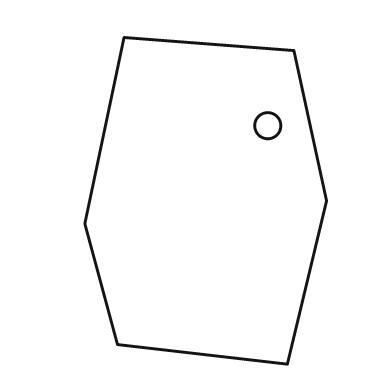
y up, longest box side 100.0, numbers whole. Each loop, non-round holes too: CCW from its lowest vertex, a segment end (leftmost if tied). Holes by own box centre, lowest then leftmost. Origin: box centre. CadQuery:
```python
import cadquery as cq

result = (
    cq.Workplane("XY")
    .moveTo(25.0, -50.0)
    .lineTo(37.0, 0.0)
    .lineTo(27.0, 46.0)
    .lineTo(-25.0, 50.0)
    .lineTo(-37.0, -7.0)
    .lineTo(-27.0, -44.0)
    .close()
    .moveTo(19.0, 23.0)
    .circle(4.0)
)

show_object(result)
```